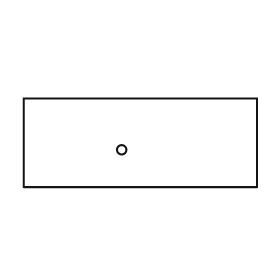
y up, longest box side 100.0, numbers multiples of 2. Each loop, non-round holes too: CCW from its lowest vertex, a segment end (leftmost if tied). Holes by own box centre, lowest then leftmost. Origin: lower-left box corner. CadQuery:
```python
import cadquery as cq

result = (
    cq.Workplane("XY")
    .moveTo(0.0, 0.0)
    .lineTo(100.0, 0.0)
    .lineTo(100.0, 38.0)
    .lineTo(0.0, 38.0)
    .close()
    .moveTo(42.0, 16.0)
    .circle(2.0)
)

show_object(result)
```